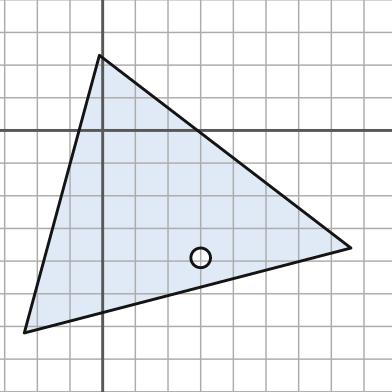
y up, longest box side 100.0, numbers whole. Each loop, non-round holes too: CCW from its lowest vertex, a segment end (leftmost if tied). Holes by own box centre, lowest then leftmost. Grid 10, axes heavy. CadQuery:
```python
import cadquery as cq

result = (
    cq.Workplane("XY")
    .moveTo(-24.0, -62.0)
    .lineTo(76.0, -36.0)
    .lineTo(-1.0, 23.0)
    .close()
    .moveTo(30.0, -39.0)
    .circle(3.0)
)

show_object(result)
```